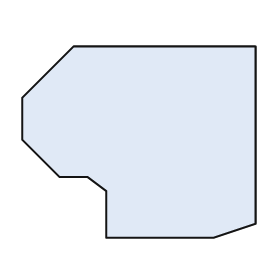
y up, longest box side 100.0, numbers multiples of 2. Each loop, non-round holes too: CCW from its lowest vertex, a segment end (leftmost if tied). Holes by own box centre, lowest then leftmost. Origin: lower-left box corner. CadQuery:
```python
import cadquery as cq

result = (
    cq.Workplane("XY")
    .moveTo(36.0, 0.0)
    .lineTo(82.0, 0.0)
    .lineTo(100.0, 6.0)
    .lineTo(100.0, 82.0)
    .lineTo(22.0, 82.0)
    .lineTo(0.0, 60.0)
    .lineTo(0.0, 42.0)
    .lineTo(16.0, 26.0)
    .lineTo(28.0, 26.0)
    .lineTo(36.0, 20.0)
    .close()
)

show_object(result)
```